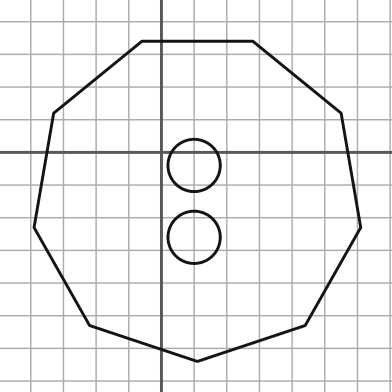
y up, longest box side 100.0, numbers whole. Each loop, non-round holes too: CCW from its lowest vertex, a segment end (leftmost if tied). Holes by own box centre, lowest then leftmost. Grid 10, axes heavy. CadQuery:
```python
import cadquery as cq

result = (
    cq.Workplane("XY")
    .moveTo(11.0, -64.0)
    .lineTo(44.0, -53.0)
    .lineTo(61.0, -23.0)
    .lineTo(55.0, 12.0)
    .lineTo(28.0, 34.0)
    .lineTo(-6.0, 34.0)
    .lineTo(-33.0, 12.0)
    .lineTo(-39.0, -23.0)
    .lineTo(-22.0, -53.0)
    .close()
    .moveTo(10.0, -26.0)
    .circle(8.0)
    .moveTo(10.0, -4.0)
    .circle(8.0)
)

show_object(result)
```